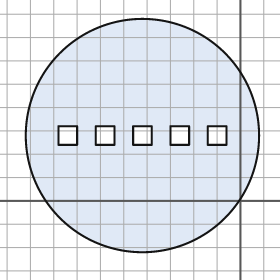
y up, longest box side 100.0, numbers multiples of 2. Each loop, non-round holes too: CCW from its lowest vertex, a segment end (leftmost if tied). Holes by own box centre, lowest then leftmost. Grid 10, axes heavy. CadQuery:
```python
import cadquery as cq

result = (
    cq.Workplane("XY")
    .moveTo(-42.0, 28.0)
    .circle(50.0)
    .moveTo(-78.0, 24.0)
    .lineTo(-70.0, 24.0)
    .lineTo(-70.0, 32.0)
    .lineTo(-78.0, 32.0)
    .close()
    .moveTo(-62.0, 24.0)
    .lineTo(-54.0, 24.0)
    .lineTo(-54.0, 32.0)
    .lineTo(-62.0, 32.0)
    .close()
    .moveTo(-46.0, 24.0)
    .lineTo(-38.0, 24.0)
    .lineTo(-38.0, 32.0)
    .lineTo(-46.0, 32.0)
    .close()
    .moveTo(-30.0, 24.0)
    .lineTo(-22.0, 24.0)
    .lineTo(-22.0, 32.0)
    .lineTo(-30.0, 32.0)
    .close()
    .moveTo(-14.0, 24.0)
    .lineTo(-6.0, 24.0)
    .lineTo(-6.0, 32.0)
    .lineTo(-14.0, 32.0)
    .close()
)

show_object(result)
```